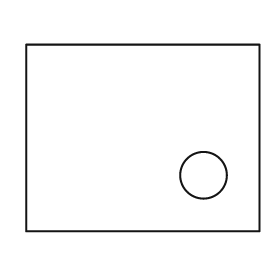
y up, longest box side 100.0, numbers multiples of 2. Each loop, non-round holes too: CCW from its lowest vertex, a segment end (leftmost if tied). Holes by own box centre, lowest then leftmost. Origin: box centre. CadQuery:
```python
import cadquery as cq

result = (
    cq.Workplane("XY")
    .moveTo(-50.0, -40.0)
    .lineTo(50.0, -40.0)
    .lineTo(50.0, 40.0)
    .lineTo(-50.0, 40.0)
    .close()
    .moveTo(26.0, -16.0)
    .circle(10.0)
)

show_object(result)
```